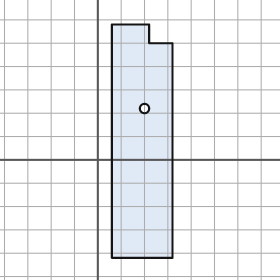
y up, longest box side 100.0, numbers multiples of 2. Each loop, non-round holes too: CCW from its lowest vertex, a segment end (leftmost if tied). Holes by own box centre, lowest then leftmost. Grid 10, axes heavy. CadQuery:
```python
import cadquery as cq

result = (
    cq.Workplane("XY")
    .moveTo(6.0, -42.0)
    .lineTo(32.0, -42.0)
    .lineTo(32.0, 50.0)
    .lineTo(22.0, 50.0)
    .lineTo(22.0, 58.0)
    .lineTo(6.0, 58.0)
    .close()
    .moveTo(20.0, 22.0)
    .circle(2.0)
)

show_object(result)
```